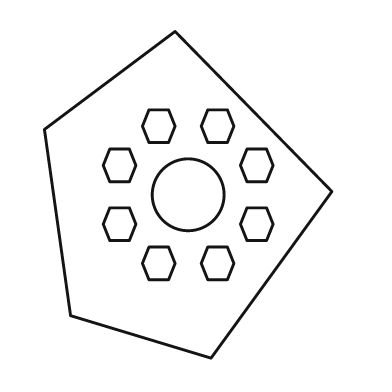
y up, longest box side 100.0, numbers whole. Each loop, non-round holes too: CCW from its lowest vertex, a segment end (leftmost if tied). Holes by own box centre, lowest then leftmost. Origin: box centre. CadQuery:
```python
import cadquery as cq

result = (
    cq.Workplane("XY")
    .moveTo(7.0, -50.0)
    .lineTo(44.0, 1.0)
    .lineTo(-4.0, 50.0)
    .lineTo(-44.0, 20.0)
    .lineTo(-36.0, -37.0)
    .close()
    .moveTo(-12.0, -26.0)
    .lineTo(-6.0, -26.0)
    .lineTo(-4.0, -21.0)
    .lineTo(-6.0, -16.0)
    .lineTo(-12.0, -16.0)
    .lineTo(-14.0, -21.0)
    .close()
    .moveTo(6.0, -26.0)
    .lineTo(12.0, -26.0)
    .lineTo(14.0, -21.0)
    .lineTo(12.0, -16.0)
    .lineTo(6.0, -16.0)
    .lineTo(4.0, -21.0)
    .close()
    .moveTo(-24.0, -14.0)
    .lineTo(-18.0, -14.0)
    .lineTo(-16.0, -9.0)
    .lineTo(-18.0, -4.0)
    .lineTo(-24.0, -4.0)
    .lineTo(-26.0, -9.0)
    .close()
    .moveTo(18.0, -14.0)
    .lineTo(24.0, -14.0)
    .lineTo(26.0, -9.0)
    .lineTo(24.0, -4.0)
    .lineTo(18.0, -4.0)
    .lineTo(16.0, -9.0)
    .close()
    .moveTo(0.0, 0.0)
    .circle(11.0)
    .moveTo(-24.0, 4.0)
    .lineTo(-18.0, 4.0)
    .lineTo(-16.0, 9.0)
    .lineTo(-18.0, 14.0)
    .lineTo(-24.0, 14.0)
    .lineTo(-26.0, 9.0)
    .close()
    .moveTo(18.0, 4.0)
    .lineTo(24.0, 4.0)
    .lineTo(26.0, 9.0)
    .lineTo(24.0, 14.0)
    .lineTo(18.0, 14.0)
    .lineTo(16.0, 9.0)
    .close()
    .moveTo(-12.0, 16.0)
    .lineTo(-6.0, 16.0)
    .lineTo(-4.0, 21.0)
    .lineTo(-6.0, 26.0)
    .lineTo(-12.0, 26.0)
    .lineTo(-14.0, 21.0)
    .close()
    .moveTo(6.0, 16.0)
    .lineTo(12.0, 16.0)
    .lineTo(14.0, 21.0)
    .lineTo(12.0, 26.0)
    .lineTo(6.0, 26.0)
    .lineTo(4.0, 21.0)
    .close()
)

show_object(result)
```